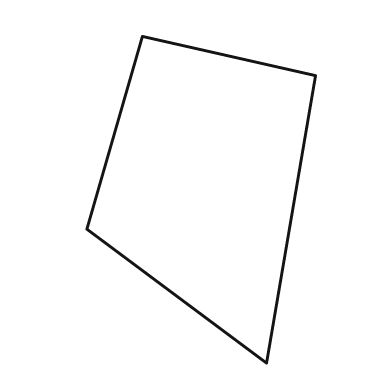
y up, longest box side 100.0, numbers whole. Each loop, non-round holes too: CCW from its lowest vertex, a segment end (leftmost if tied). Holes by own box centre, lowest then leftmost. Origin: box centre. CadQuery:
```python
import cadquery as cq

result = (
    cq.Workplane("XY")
    .moveTo(20.0, -50.0)
    .lineTo(35.0, 38.0)
    .lineTo(-18.0, 50.0)
    .lineTo(-35.0, -9.0)
    .close()
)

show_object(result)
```